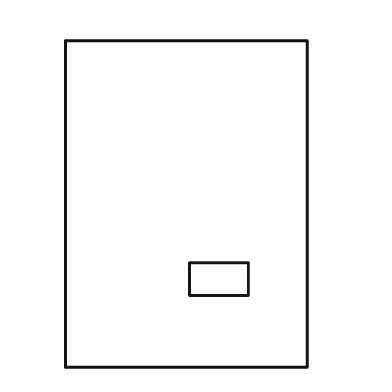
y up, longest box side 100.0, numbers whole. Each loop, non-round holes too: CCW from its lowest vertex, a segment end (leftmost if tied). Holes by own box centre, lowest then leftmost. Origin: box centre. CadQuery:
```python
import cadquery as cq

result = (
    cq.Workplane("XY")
    .moveTo(-37.0, -50.0)
    .lineTo(37.0, -50.0)
    .lineTo(37.0, 50.0)
    .lineTo(-37.0, 50.0)
    .close()
    .moveTo(1.0, -28.0)
    .lineTo(19.0, -28.0)
    .lineTo(19.0, -18.0)
    .lineTo(1.0, -18.0)
    .close()
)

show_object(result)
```